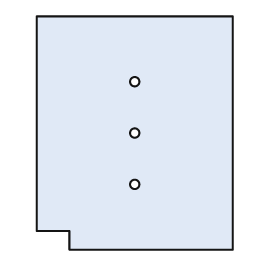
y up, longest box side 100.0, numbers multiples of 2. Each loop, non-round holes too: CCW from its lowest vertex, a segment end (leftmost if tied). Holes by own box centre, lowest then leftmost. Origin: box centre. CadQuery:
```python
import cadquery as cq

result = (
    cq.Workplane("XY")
    .moveTo(-28.0, -50.0)
    .lineTo(42.0, -50.0)
    .lineTo(42.0, 50.0)
    .lineTo(-42.0, 50.0)
    .lineTo(-42.0, -42.0)
    .lineTo(-28.0, -42.0)
    .close()
    .moveTo(0.0, -22.0)
    .circle(2.0)
    .moveTo(0.0, 0.0)
    .circle(2.0)
    .moveTo(0.0, 22.0)
    .circle(2.0)
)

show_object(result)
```